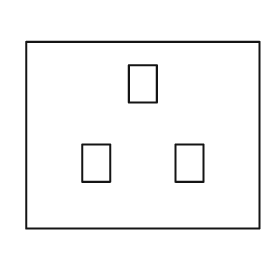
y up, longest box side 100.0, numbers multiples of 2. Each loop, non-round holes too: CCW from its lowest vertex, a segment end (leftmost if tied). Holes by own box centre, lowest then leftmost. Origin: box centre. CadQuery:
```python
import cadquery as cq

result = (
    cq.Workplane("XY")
    .moveTo(-50.0, -40.0)
    .lineTo(50.0, -40.0)
    .lineTo(50.0, 40.0)
    .lineTo(-50.0, 40.0)
    .close()
    .moveTo(-26.0, -20.0)
    .lineTo(-14.0, -20.0)
    .lineTo(-14.0, -4.0)
    .lineTo(-26.0, -4.0)
    .close()
    .moveTo(14.0, -20.0)
    .lineTo(26.0, -20.0)
    .lineTo(26.0, -4.0)
    .lineTo(14.0, -4.0)
    .close()
    .moveTo(-6.0, 14.0)
    .lineTo(6.0, 14.0)
    .lineTo(6.0, 30.0)
    .lineTo(-6.0, 30.0)
    .close()
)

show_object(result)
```